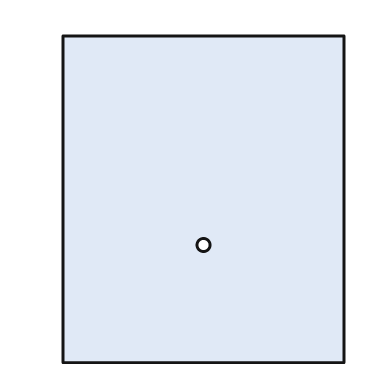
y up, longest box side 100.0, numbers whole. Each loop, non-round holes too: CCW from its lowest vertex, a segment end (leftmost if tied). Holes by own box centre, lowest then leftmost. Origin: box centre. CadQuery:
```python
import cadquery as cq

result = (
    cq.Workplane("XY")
    .moveTo(-43.0, -50.0)
    .lineTo(43.0, -50.0)
    .lineTo(43.0, 50.0)
    .lineTo(-43.0, 50.0)
    .close()
    .moveTo(0.0, -14.0)
    .circle(2.0)
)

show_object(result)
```